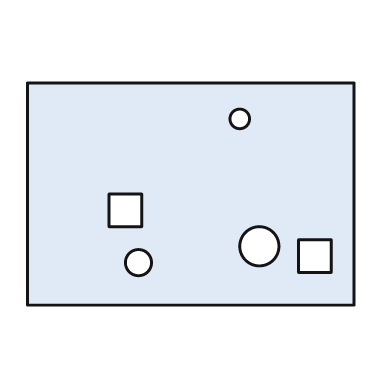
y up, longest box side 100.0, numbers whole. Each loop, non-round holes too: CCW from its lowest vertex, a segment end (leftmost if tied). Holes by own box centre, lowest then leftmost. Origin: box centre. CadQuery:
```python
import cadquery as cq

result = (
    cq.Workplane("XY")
    .moveTo(-50.0, -34.0)
    .lineTo(50.0, -34.0)
    .lineTo(50.0, 34.0)
    .lineTo(-50.0, 34.0)
    .close()
    .moveTo(-16.0, -21.0)
    .circle(4.0)
    .moveTo(33.0, -24.0)
    .lineTo(43.0, -24.0)
    .lineTo(43.0, -14.0)
    .lineTo(33.0, -14.0)
    .close()
    .moveTo(21.0, -16.0)
    .circle(6.0)
    .moveTo(-25.0, -10.0)
    .lineTo(-15.0, -10.0)
    .lineTo(-15.0, 0.0)
    .lineTo(-25.0, 0.0)
    .close()
    .moveTo(15.0, 23.0)
    .circle(3.0)
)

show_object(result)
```